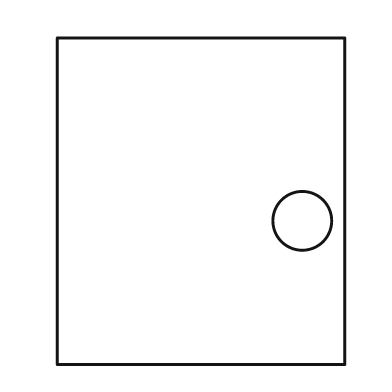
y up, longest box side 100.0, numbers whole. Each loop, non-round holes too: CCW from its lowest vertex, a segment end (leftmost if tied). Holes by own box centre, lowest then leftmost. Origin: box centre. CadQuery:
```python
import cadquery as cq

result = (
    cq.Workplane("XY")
    .moveTo(-44.0, -50.0)
    .lineTo(44.0, -50.0)
    .lineTo(44.0, 50.0)
    .lineTo(-44.0, 50.0)
    .close()
    .moveTo(31.0, -6.0)
    .circle(9.0)
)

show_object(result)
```